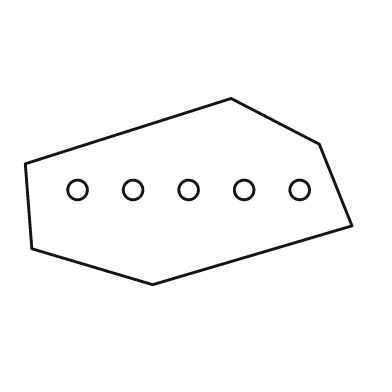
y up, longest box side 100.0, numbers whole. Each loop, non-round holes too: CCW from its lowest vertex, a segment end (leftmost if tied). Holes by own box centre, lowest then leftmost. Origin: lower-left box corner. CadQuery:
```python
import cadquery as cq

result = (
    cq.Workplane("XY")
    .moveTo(39.0, 0.0)
    .lineTo(100.0, 18.0)
    .lineTo(90.0, 43.0)
    .lineTo(63.0, 57.0)
    .lineTo(0.0, 37.0)
    .lineTo(2.0, 11.0)
    .close()
    .moveTo(16.0, 29.0)
    .circle(3.0)
    .moveTo(33.0, 29.0)
    .circle(3.0)
    .moveTo(50.0, 29.0)
    .circle(3.0)
    .moveTo(67.0, 29.0)
    .circle(3.0)
    .moveTo(84.0, 29.0)
    .circle(3.0)
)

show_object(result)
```